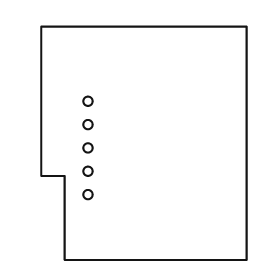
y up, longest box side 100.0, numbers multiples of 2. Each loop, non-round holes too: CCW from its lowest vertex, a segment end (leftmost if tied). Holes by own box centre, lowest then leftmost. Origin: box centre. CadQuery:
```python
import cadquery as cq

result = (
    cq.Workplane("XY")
    .moveTo(-34.0, -50.0)
    .lineTo(44.0, -50.0)
    .lineTo(44.0, 50.0)
    .lineTo(-44.0, 50.0)
    .lineTo(-44.0, -14.0)
    .lineTo(-34.0, -14.0)
    .close()
    .moveTo(-24.0, -22.0)
    .circle(2.0)
    .moveTo(-24.0, -12.0)
    .circle(2.0)
    .moveTo(-24.0, -2.0)
    .circle(2.0)
    .moveTo(-24.0, 8.0)
    .circle(2.0)
    .moveTo(-24.0, 18.0)
    .circle(2.0)
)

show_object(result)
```